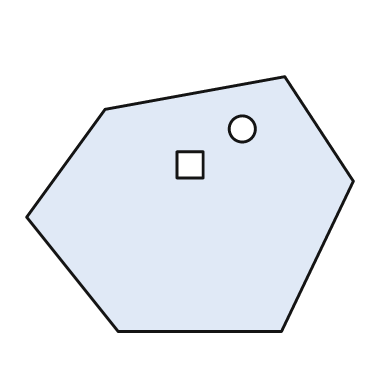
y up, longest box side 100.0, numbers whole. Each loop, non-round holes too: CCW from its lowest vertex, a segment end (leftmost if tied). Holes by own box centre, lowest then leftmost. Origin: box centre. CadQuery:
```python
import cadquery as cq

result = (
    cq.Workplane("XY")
    .moveTo(-22.0, -39.0)
    .lineTo(28.0, -39.0)
    .lineTo(50.0, 7.0)
    .lineTo(29.0, 39.0)
    .lineTo(-26.0, 29.0)
    .lineTo(-50.0, -4.0)
    .close()
    .moveTo(-4.0, 8.0)
    .lineTo(4.0, 8.0)
    .lineTo(4.0, 16.0)
    .lineTo(-4.0, 16.0)
    .close()
    .moveTo(16.0, 23.0)
    .circle(4.0)
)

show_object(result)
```